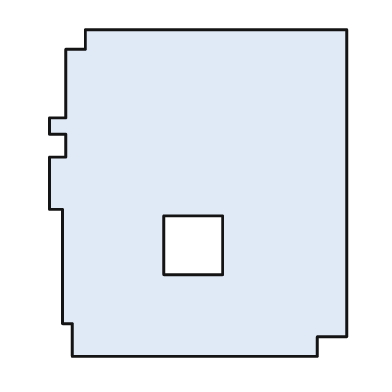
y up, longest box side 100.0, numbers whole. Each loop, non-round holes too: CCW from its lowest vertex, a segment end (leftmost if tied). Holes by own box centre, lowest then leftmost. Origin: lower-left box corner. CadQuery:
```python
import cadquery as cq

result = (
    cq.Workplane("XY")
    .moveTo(7.0, 0.0)
    .lineTo(82.0, 0.0)
    .lineTo(82.0, 6.0)
    .lineTo(91.0, 6.0)
    .lineTo(91.0, 100.0)
    .lineTo(11.0, 100.0)
    .lineTo(11.0, 94.0)
    .lineTo(5.0, 94.0)
    .lineTo(5.0, 73.0)
    .lineTo(0.0, 73.0)
    .lineTo(0.0, 68.0)
    .lineTo(5.0, 68.0)
    .lineTo(5.0, 61.0)
    .lineTo(0.0, 61.0)
    .lineTo(0.0, 45.0)
    .lineTo(4.0, 45.0)
    .lineTo(4.0, 10.0)
    .lineTo(7.0, 10.0)
    .close()
    .moveTo(35.0, 25.0)
    .lineTo(53.0, 25.0)
    .lineTo(53.0, 43.0)
    .lineTo(35.0, 43.0)
    .close()
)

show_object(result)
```